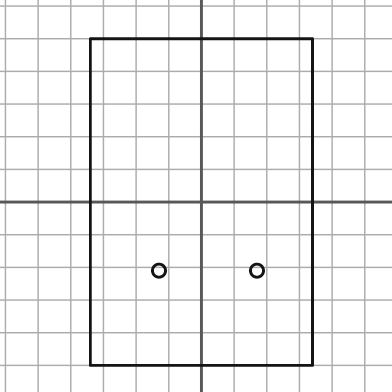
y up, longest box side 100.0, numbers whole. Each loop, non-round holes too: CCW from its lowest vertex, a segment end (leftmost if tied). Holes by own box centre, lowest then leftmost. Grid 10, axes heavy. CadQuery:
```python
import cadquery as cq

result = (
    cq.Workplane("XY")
    .moveTo(-34.0, -50.0)
    .lineTo(34.0, -50.0)
    .lineTo(34.0, 50.0)
    .lineTo(-34.0, 50.0)
    .close()
    .moveTo(-13.0, -21.0)
    .circle(2.0)
    .moveTo(17.0, -21.0)
    .circle(2.0)
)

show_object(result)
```